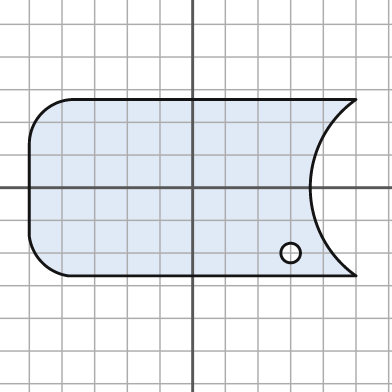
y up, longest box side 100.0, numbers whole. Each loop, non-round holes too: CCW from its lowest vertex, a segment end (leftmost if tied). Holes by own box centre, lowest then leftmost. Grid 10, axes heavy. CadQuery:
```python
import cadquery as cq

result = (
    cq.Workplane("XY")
    .moveTo(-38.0, -27.0)
    .lineTo(50.0, -27.0)
    .threePointArc((36.0, 0.0), (50.0, 27.0))
    .lineTo(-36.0, 27.0)
    .threePointArc((-46.0, 23.0), (-50.0, 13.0))
    .lineTo(-50.0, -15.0)
    .threePointArc((-46.0, -23.0), (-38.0, -27.0))
    .close()
    .moveTo(30.0, -20.0)
    .circle(3.0)
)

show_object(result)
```